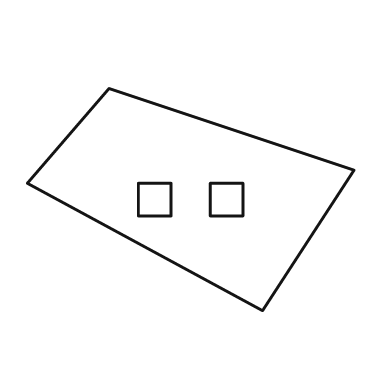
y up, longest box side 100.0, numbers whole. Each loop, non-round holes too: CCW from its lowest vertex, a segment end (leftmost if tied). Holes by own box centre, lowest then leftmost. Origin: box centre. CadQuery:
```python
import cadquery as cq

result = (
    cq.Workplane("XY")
    .moveTo(22.0, -34.0)
    .lineTo(50.0, 9.0)
    .lineTo(-25.0, 34.0)
    .lineTo(-50.0, 5.0)
    .close()
    .moveTo(-16.0, -5.0)
    .lineTo(-6.0, -5.0)
    .lineTo(-6.0, 5.0)
    .lineTo(-16.0, 5.0)
    .close()
    .moveTo(6.0, -5.0)
    .lineTo(16.0, -5.0)
    .lineTo(16.0, 5.0)
    .lineTo(6.0, 5.0)
    .close()
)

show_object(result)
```